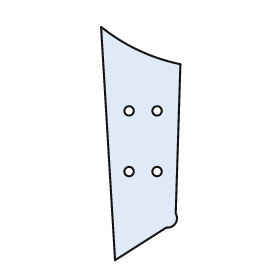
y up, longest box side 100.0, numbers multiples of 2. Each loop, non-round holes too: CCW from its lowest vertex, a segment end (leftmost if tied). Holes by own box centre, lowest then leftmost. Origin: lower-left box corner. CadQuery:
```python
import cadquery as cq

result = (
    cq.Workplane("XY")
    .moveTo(6.0, 0.0)
    .lineTo(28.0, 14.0)
    .threePointArc((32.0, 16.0), (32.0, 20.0))
    .lineTo(34.0, 84.0)
    .threePointArc((16.0, 90.0), (0.0, 100.0))
    .close()
    .moveTo(12.0, 38.0)
    .circle(2.0)
    .moveTo(24.0, 38.0)
    .circle(2.0)
    .moveTo(12.0, 64.0)
    .circle(2.0)
    .moveTo(24.0, 64.0)
    .circle(2.0)
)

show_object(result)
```